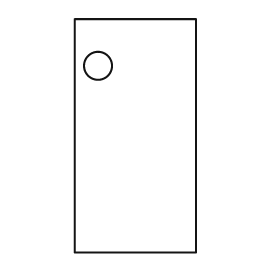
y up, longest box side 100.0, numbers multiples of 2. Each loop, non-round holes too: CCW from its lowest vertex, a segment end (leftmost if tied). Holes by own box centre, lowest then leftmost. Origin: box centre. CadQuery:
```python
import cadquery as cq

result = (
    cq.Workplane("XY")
    .moveTo(-26.0, -50.0)
    .lineTo(26.0, -50.0)
    .lineTo(26.0, 50.0)
    .lineTo(-26.0, 50.0)
    .close()
    .moveTo(-16.0, 30.0)
    .circle(6.0)
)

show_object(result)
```